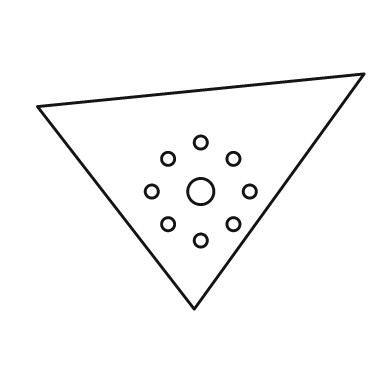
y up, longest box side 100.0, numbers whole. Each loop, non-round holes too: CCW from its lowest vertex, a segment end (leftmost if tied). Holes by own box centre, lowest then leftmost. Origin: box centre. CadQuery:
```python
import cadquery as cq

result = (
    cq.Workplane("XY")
    .moveTo(-2.0, -36.0)
    .lineTo(50.0, 36.0)
    .lineTo(-50.0, 26.0)
    .close()
    .moveTo(0.0, -15.0)
    .circle(2.0)
    .moveTo(-10.0, -10.0)
    .circle(2.0)
    .moveTo(10.0, -10.0)
    .circle(2.0)
    .moveTo(-15.0, 0.0)
    .circle(2.0)
    .moveTo(0.0, 0.0)
    .circle(4.0)
    .moveTo(15.0, 0.0)
    .circle(2.0)
    .moveTo(-10.0, 10.0)
    .circle(2.0)
    .moveTo(10.0, 10.0)
    .circle(2.0)
    .moveTo(0.0, 15.0)
    .circle(2.0)
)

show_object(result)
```